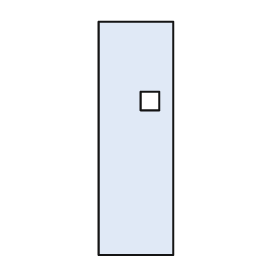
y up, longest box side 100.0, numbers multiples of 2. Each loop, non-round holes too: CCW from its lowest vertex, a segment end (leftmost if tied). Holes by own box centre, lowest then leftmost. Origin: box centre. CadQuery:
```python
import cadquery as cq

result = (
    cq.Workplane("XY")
    .moveTo(-16.0, -50.0)
    .lineTo(16.0, -50.0)
    .lineTo(16.0, 50.0)
    .lineTo(-16.0, 50.0)
    .close()
    .moveTo(2.0, 12.0)
    .lineTo(10.0, 12.0)
    .lineTo(10.0, 20.0)
    .lineTo(2.0, 20.0)
    .close()
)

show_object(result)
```